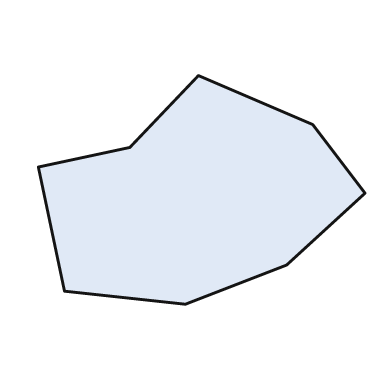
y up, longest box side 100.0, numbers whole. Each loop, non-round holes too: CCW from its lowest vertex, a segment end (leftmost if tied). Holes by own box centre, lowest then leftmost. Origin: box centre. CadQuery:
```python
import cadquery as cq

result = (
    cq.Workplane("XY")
    .moveTo(-5.0, -35.0)
    .lineTo(26.0, -23.0)
    .lineTo(50.0, -1.0)
    .lineTo(34.0, 20.0)
    .lineTo(-1.0, 35.0)
    .lineTo(-22.0, 13.0)
    .lineTo(-50.0, 7.0)
    .lineTo(-42.0, -31.0)
    .close()
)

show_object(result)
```